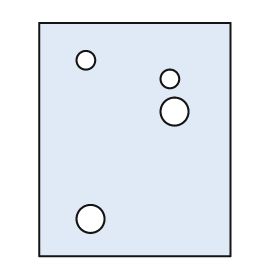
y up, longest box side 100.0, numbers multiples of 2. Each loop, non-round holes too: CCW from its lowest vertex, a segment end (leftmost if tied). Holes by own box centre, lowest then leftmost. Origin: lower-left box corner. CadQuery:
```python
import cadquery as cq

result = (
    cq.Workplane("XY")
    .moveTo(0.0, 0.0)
    .lineTo(82.0, 0.0)
    .lineTo(82.0, 100.0)
    .lineTo(0.0, 100.0)
    .close()
    .moveTo(22.0, 16.0)
    .circle(6.0)
    .moveTo(58.0, 62.0)
    .circle(6.0)
    .moveTo(56.0, 76.0)
    .circle(4.0)
    .moveTo(20.0, 84.0)
    .circle(4.0)
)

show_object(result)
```